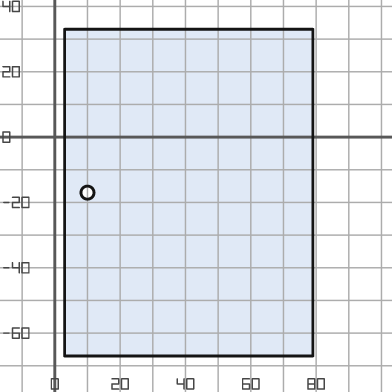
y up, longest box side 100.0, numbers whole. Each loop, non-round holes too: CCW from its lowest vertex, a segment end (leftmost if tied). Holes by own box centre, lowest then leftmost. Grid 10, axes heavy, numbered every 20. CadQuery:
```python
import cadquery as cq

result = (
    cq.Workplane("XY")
    .moveTo(3.0, -67.0)
    .lineTo(79.0, -67.0)
    .lineTo(79.0, 33.0)
    .lineTo(3.0, 33.0)
    .close()
    .moveTo(10.0, -17.0)
    .circle(2.0)
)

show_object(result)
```